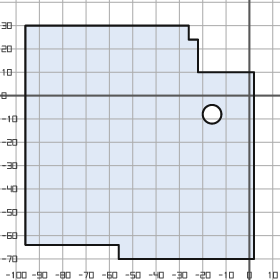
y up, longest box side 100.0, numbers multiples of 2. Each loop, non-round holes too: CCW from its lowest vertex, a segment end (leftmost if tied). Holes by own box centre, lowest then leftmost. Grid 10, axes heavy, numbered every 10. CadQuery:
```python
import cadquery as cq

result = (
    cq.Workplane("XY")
    .moveTo(-56.0, -70.0)
    .lineTo(2.0, -70.0)
    .lineTo(2.0, 10.0)
    .lineTo(-22.0, 10.0)
    .lineTo(-22.0, 24.0)
    .lineTo(-26.0, 24.0)
    .lineTo(-26.0, 30.0)
    .lineTo(-96.0, 30.0)
    .lineTo(-96.0, -64.0)
    .lineTo(-56.0, -64.0)
    .close()
    .moveTo(-16.0, -8.0)
    .circle(4.0)
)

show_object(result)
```